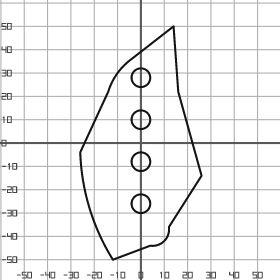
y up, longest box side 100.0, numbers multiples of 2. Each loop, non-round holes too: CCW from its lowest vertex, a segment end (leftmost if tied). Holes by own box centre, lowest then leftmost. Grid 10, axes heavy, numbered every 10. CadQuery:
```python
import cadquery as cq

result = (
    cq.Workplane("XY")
    .moveTo(-12.0, -50.0)
    .lineTo(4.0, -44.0)
    .threePointArc((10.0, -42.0), (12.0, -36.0))
    .lineTo(26.0, -14.0)
    .lineTo(16.0, 22.0)
    .lineTo(14.0, 50.0)
    .lineTo(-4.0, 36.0)
    .threePointArc((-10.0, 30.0), (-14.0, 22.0))
    .lineTo(-26.0, -4.0)
    .threePointArc((-22.0, -28.0), (-12.0, -50.0))
    .close()
    .moveTo(0.0, -26.0)
    .circle(4.0)
    .moveTo(0.0, -8.0)
    .circle(4.0)
    .moveTo(0.0, 10.0)
    .circle(4.0)
    .moveTo(0.0, 28.0)
    .circle(4.0)
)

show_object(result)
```